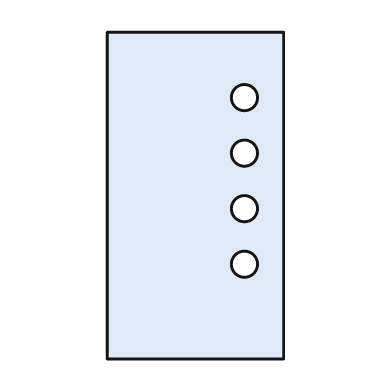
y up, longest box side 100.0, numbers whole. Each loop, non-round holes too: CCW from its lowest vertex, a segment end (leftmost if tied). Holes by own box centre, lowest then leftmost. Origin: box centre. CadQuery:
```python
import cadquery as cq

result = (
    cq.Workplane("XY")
    .moveTo(-27.0, -50.0)
    .lineTo(27.0, -50.0)
    .lineTo(27.0, 50.0)
    .lineTo(-27.0, 50.0)
    .close()
    .moveTo(15.0, -21.0)
    .circle(4.0)
    .moveTo(15.0, -4.0)
    .circle(4.0)
    .moveTo(15.0, 13.0)
    .circle(4.0)
    .moveTo(15.0, 30.0)
    .circle(4.0)
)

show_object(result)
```